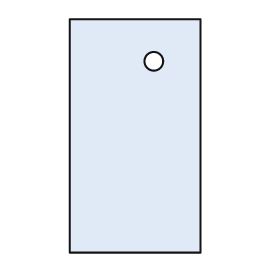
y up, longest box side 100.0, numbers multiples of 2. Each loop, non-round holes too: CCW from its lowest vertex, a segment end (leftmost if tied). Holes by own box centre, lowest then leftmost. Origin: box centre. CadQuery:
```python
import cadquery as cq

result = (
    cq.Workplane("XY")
    .moveTo(-28.0, -50.0)
    .lineTo(28.0, -50.0)
    .lineTo(28.0, 50.0)
    .lineTo(-28.0, 50.0)
    .close()
    .moveTo(8.0, 32.0)
    .circle(4.0)
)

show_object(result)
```